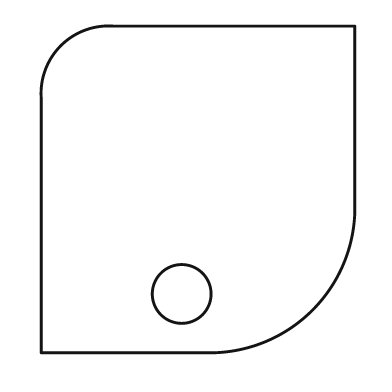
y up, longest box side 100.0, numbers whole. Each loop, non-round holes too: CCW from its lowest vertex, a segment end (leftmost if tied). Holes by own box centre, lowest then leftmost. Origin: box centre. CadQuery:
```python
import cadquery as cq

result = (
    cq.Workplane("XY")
    .moveTo(-48.0, -50.0)
    .lineTo(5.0, -50.0)
    .threePointArc((35.0, -37.0), (48.0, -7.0))
    .lineTo(48.0, 50.0)
    .lineTo(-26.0, 50.0)
    .threePointArc((-42.0, 44.0), (-48.0, 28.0))
    .close()
    .moveTo(-5.0, -32.0)
    .circle(9.0)
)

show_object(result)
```